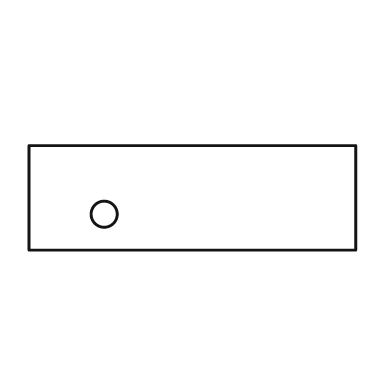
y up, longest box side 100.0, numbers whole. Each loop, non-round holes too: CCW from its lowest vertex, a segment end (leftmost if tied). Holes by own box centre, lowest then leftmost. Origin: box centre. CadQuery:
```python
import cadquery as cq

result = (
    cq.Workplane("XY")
    .moveTo(-50.0, -16.0)
    .lineTo(50.0, -16.0)
    .lineTo(50.0, 16.0)
    .lineTo(-50.0, 16.0)
    .close()
    .moveTo(-27.0, -5.0)
    .circle(4.0)
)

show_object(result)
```